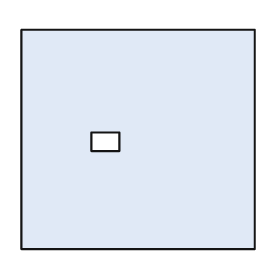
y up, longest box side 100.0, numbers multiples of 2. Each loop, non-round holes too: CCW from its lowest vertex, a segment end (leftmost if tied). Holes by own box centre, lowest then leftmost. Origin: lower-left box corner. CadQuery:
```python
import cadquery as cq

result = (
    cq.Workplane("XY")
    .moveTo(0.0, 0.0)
    .lineTo(100.0, 0.0)
    .lineTo(100.0, 94.0)
    .lineTo(0.0, 94.0)
    .close()
    .moveTo(30.0, 42.0)
    .lineTo(42.0, 42.0)
    .lineTo(42.0, 50.0)
    .lineTo(30.0, 50.0)
    .close()
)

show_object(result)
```